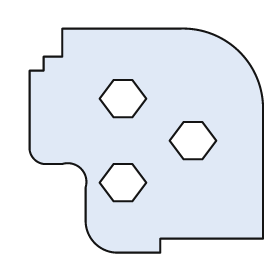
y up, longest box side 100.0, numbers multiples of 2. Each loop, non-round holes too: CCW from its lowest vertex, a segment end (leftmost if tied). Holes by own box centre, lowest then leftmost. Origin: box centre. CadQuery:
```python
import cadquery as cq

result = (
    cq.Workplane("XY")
    .moveTo(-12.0, -48.0)
    .lineTo(6.0, -48.0)
    .lineTo(6.0, -42.0)
    .lineTo(50.0, -42.0)
    .lineTo(50.0, 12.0)
    .threePointArc((40.0, 38.0), (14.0, 48.0))
    .lineTo(-36.0, 48.0)
    .lineTo(-36.0, 36.0)
    .lineTo(-44.0, 36.0)
    .lineTo(-44.0, 30.0)
    .lineTo(-50.0, 30.0)
    .lineTo(-50.0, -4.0)
    .threePointArc((-48.0, -8.0), (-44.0, -10.0))
    .lineTo(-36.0, -10.0)
    .threePointArc((-28.0, -12.0), (-26.0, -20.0))
    .lineTo(-26.0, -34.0)
    .threePointArc((-22.0, -44.0), (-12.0, -48.0))
    .close()
    .moveTo(-14.0, -26.0)
    .lineTo(-6.0, -26.0)
    .lineTo(0.0, -18.0)
    .lineTo(-6.0, -10.0)
    .lineTo(-14.0, -10.0)
    .lineTo(-20.0, -18.0)
    .close()
    .moveTo(16.0, -8.0)
    .lineTo(24.0, -8.0)
    .lineTo(30.0, 0.0)
    .lineTo(24.0, 8.0)
    .lineTo(16.0, 8.0)
    .lineTo(10.0, 0.0)
    .close()
    .moveTo(-14.0, 10.0)
    .lineTo(-6.0, 10.0)
    .lineTo(0.0, 18.0)
    .lineTo(-6.0, 26.0)
    .lineTo(-14.0, 26.0)
    .lineTo(-20.0, 18.0)
    .close()
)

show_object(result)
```